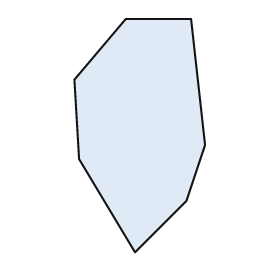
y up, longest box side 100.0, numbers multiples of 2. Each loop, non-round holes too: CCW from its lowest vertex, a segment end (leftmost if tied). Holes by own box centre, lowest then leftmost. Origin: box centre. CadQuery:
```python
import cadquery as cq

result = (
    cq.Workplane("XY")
    .moveTo(-2.0, -50.0)
    .lineTo(20.0, -28.0)
    .lineTo(28.0, -4.0)
    .lineTo(22.0, 50.0)
    .lineTo(-6.0, 50.0)
    .lineTo(-28.0, 24.0)
    .lineTo(-26.0, -10.0)
    .close()
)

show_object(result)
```